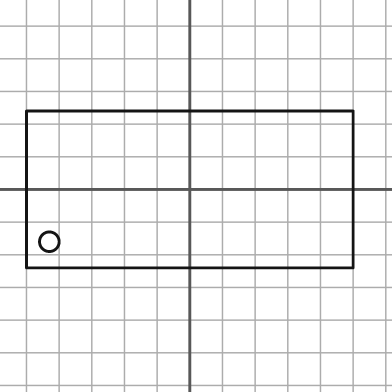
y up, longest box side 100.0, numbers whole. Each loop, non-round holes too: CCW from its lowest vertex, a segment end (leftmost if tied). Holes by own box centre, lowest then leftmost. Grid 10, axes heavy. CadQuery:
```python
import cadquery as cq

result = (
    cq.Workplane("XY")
    .moveTo(-50.0, -24.0)
    .lineTo(50.0, -24.0)
    .lineTo(50.0, 24.0)
    .lineTo(-50.0, 24.0)
    .close()
    .moveTo(-43.0, -16.0)
    .circle(3.0)
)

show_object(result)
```